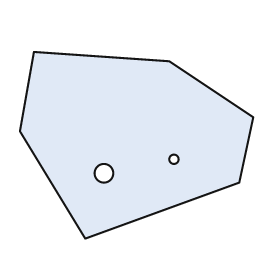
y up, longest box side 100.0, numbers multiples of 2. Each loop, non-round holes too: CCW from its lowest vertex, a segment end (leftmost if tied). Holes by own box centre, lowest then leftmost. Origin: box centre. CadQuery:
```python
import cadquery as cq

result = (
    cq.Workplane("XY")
    .moveTo(-22.0, -40.0)
    .lineTo(44.0, -16.0)
    .lineTo(50.0, 12.0)
    .lineTo(14.0, 36.0)
    .lineTo(-44.0, 40.0)
    .lineTo(-50.0, 6.0)
    .close()
    .moveTo(-14.0, -12.0)
    .circle(4.0)
    .moveTo(16.0, -6.0)
    .circle(2.0)
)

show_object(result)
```